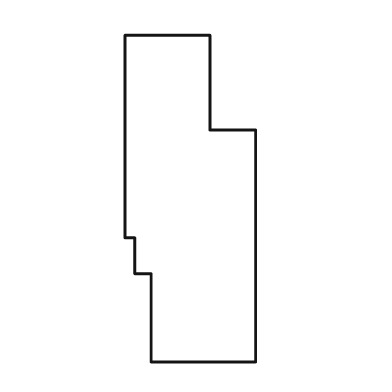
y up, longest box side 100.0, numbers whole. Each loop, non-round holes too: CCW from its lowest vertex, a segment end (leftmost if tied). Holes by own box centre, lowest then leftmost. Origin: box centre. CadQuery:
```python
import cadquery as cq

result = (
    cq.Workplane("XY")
    .moveTo(-12.0, -50.0)
    .lineTo(20.0, -50.0)
    .lineTo(20.0, 21.0)
    .lineTo(6.0, 21.0)
    .lineTo(6.0, 50.0)
    .lineTo(-20.0, 50.0)
    .lineTo(-20.0, -12.0)
    .lineTo(-17.0, -12.0)
    .lineTo(-17.0, -23.0)
    .lineTo(-12.0, -23.0)
    .close()
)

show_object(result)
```